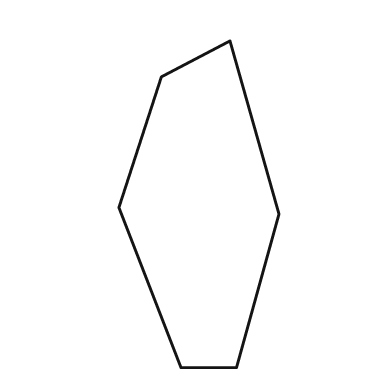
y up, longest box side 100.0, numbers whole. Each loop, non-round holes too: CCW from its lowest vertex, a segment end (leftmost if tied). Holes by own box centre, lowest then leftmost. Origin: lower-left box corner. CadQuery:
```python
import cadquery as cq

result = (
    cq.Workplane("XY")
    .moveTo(19.0, 0.0)
    .lineTo(36.0, 0.0)
    .lineTo(49.0, 47.0)
    .lineTo(34.0, 100.0)
    .lineTo(13.0, 89.0)
    .lineTo(0.0, 49.0)
    .close()
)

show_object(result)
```